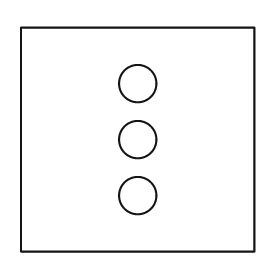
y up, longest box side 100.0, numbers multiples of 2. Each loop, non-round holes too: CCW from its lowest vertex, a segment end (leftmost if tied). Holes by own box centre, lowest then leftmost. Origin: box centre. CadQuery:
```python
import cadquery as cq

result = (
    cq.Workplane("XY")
    .moveTo(-50.0, -48.0)
    .lineTo(50.0, -48.0)
    .lineTo(50.0, 48.0)
    .lineTo(-50.0, 48.0)
    .close()
    .moveTo(0.0, -24.0)
    .circle(8.0)
    .moveTo(0.0, 0.0)
    .circle(8.0)
    .moveTo(0.0, 24.0)
    .circle(8.0)
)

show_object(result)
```